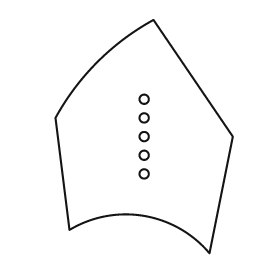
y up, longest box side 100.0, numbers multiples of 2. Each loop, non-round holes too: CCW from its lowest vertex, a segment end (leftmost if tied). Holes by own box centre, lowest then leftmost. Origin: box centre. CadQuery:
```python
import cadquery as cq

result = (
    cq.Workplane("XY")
    .moveTo(28.0, -50.0)
    .lineTo(38.0, 0.0)
    .lineTo(4.0, 50.0)
    .threePointArc((-20.0, 32.0), (-38.0, 8.0))
    .lineTo(-32.0, -40.0)
    .threePointArc((0.0, -34.0), (28.0, -50.0))
    .close()
    .moveTo(0.0, -16.0)
    .circle(2.0)
    .moveTo(0.0, -8.0)
    .circle(2.0)
    .moveTo(0.0, 0.0)
    .circle(2.0)
    .moveTo(0.0, 8.0)
    .circle(2.0)
    .moveTo(0.0, 16.0)
    .circle(2.0)
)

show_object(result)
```